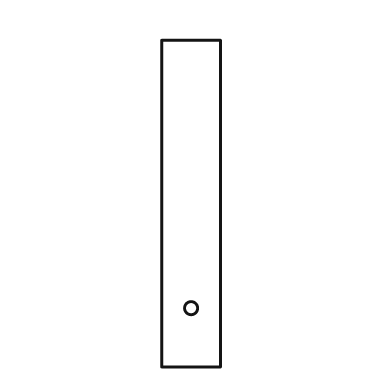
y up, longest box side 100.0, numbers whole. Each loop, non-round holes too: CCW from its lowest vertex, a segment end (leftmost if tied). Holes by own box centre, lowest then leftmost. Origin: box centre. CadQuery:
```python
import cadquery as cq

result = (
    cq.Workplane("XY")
    .moveTo(-9.0, -50.0)
    .lineTo(9.0, -50.0)
    .lineTo(9.0, 50.0)
    .lineTo(-9.0, 50.0)
    .close()
    .moveTo(0.0, -32.0)
    .circle(2.0)
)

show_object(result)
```